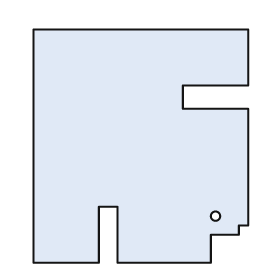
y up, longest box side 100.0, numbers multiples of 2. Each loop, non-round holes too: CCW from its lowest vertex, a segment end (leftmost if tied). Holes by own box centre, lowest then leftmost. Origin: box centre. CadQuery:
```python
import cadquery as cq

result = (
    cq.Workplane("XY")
    .moveTo(-46.0, -50.0)
    .lineTo(-18.0, -50.0)
    .lineTo(-18.0, -26.0)
    .lineTo(-10.0, -26.0)
    .lineTo(-10.0, -50.0)
    .lineTo(30.0, -50.0)
    .lineTo(30.0, -38.0)
    .lineTo(42.0, -38.0)
    .lineTo(42.0, -34.0)
    .lineTo(46.0, -34.0)
    .lineTo(46.0, 16.0)
    .lineTo(18.0, 16.0)
    .lineTo(18.0, 26.0)
    .lineTo(46.0, 26.0)
    .lineTo(46.0, 50.0)
    .lineTo(-46.0, 50.0)
    .close()
    .moveTo(32.0, -30.0)
    .circle(2.0)
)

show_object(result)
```